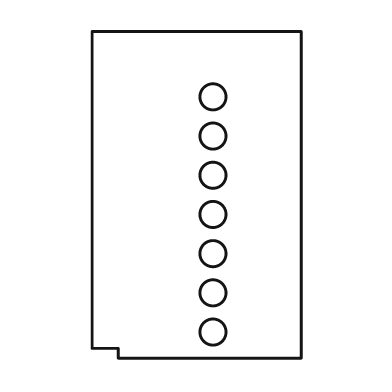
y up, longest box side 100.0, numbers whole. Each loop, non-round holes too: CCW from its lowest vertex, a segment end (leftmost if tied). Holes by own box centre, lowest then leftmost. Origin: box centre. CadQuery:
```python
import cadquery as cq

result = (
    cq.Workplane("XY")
    .moveTo(-24.0, -50.0)
    .lineTo(32.0, -50.0)
    .lineTo(32.0, 50.0)
    .lineTo(-32.0, 50.0)
    .lineTo(-32.0, -47.0)
    .lineTo(-24.0, -47.0)
    .close()
    .moveTo(5.0, -42.0)
    .circle(4.0)
    .moveTo(5.0, -30.0)
    .circle(4.0)
    .moveTo(5.0, -18.0)
    .circle(4.0)
    .moveTo(5.0, -6.0)
    .circle(4.0)
    .moveTo(5.0, 6.0)
    .circle(4.0)
    .moveTo(5.0, 18.0)
    .circle(4.0)
    .moveTo(5.0, 30.0)
    .circle(4.0)
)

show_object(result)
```